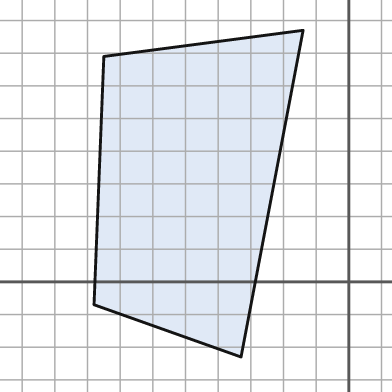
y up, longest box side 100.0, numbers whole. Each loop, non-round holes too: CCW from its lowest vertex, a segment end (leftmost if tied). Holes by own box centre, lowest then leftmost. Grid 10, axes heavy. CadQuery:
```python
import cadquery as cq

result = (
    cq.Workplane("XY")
    .moveTo(-33.0, -23.0)
    .lineTo(-14.0, 77.0)
    .lineTo(-75.0, 69.0)
    .lineTo(-78.0, -7.0)
    .close()
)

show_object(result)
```